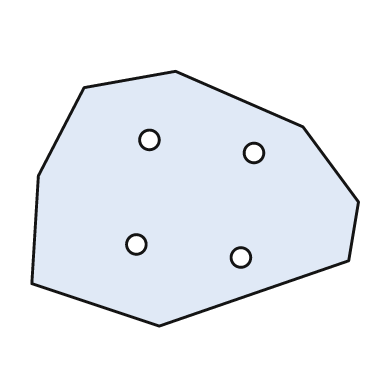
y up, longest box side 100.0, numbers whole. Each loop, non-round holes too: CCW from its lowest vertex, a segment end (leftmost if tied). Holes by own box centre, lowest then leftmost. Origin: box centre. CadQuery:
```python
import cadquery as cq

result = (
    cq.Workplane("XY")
    .moveTo(-11.0, -39.0)
    .lineTo(47.0, -19.0)
    .lineTo(50.0, -1.0)
    .lineTo(33.0, 22.0)
    .lineTo(-6.0, 39.0)
    .lineTo(-34.0, 34.0)
    .lineTo(-48.0, 7.0)
    .lineTo(-50.0, -26.0)
    .close()
    .moveTo(14.0, -18.0)
    .circle(3.0)
    .moveTo(-18.0, -14.0)
    .circle(3.0)
    .moveTo(18.0, 14.0)
    .circle(3.0)
    .moveTo(-14.0, 18.0)
    .circle(3.0)
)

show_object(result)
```